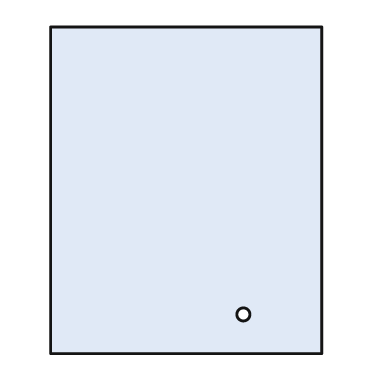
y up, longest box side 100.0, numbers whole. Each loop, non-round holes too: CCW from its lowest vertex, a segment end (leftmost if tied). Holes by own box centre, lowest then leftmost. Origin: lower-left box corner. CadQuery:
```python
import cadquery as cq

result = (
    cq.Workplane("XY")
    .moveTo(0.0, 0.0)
    .lineTo(83.0, 0.0)
    .lineTo(83.0, 100.0)
    .lineTo(0.0, 100.0)
    .close()
    .moveTo(59.0, 12.0)
    .circle(2.0)
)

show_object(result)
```